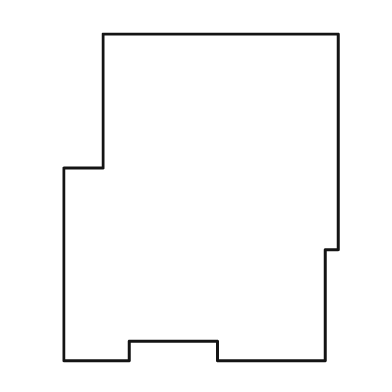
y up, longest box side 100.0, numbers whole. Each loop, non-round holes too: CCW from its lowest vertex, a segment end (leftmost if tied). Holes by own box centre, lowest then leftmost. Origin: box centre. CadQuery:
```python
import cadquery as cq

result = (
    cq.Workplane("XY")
    .moveTo(-42.0, -50.0)
    .lineTo(-22.0, -50.0)
    .lineTo(-22.0, -44.0)
    .lineTo(5.0, -44.0)
    .lineTo(5.0, -50.0)
    .lineTo(38.0, -50.0)
    .lineTo(38.0, -16.0)
    .lineTo(42.0, -16.0)
    .lineTo(42.0, 50.0)
    .lineTo(-30.0, 50.0)
    .lineTo(-30.0, 9.0)
    .lineTo(-42.0, 9.0)
    .close()
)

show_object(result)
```